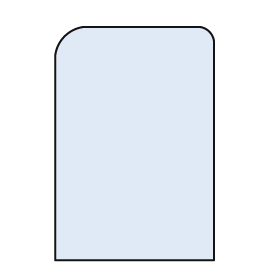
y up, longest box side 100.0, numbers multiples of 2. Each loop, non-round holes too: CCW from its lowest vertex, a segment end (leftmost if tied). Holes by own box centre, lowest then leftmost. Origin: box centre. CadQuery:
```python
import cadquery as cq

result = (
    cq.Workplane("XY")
    .moveTo(-34.0, -50.0)
    .lineTo(34.0, -50.0)
    .lineTo(34.0, 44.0)
    .threePointArc((32.0, 48.0), (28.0, 50.0))
    .lineTo(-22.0, 50.0)
    .threePointArc((-30.0, 46.0), (-34.0, 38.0))
    .close()
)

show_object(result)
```